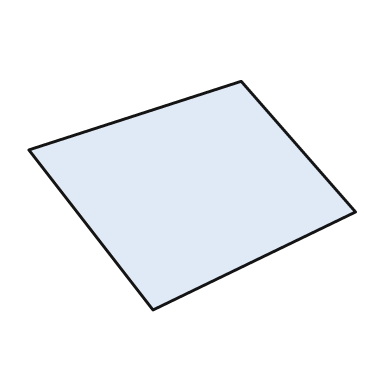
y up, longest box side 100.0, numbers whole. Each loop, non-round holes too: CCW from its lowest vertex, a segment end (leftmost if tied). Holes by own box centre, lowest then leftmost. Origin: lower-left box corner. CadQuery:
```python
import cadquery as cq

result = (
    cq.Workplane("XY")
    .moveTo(38.0, 0.0)
    .lineTo(100.0, 30.0)
    .lineTo(65.0, 70.0)
    .lineTo(0.0, 49.0)
    .close()
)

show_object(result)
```